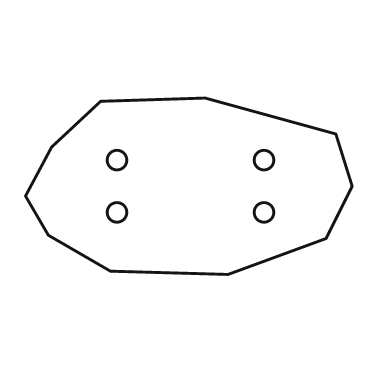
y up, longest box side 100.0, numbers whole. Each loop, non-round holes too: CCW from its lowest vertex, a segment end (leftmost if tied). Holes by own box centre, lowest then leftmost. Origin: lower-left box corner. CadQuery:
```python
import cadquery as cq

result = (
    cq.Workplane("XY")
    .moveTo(62.0, 0.0)
    .lineTo(92.0, 11.0)
    .lineTo(100.0, 27.0)
    .lineTo(95.0, 43.0)
    .lineTo(55.0, 54.0)
    .lineTo(23.0, 53.0)
    .lineTo(8.0, 39.0)
    .lineTo(0.0, 24.0)
    .lineTo(7.0, 12.0)
    .lineTo(26.0, 1.0)
    .close()
    .moveTo(28.0, 19.0)
    .circle(3.0)
    .moveTo(73.0, 19.0)
    .circle(3.0)
    .moveTo(28.0, 35.0)
    .circle(3.0)
    .moveTo(73.0, 35.0)
    .circle(3.0)
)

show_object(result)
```